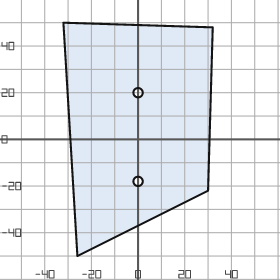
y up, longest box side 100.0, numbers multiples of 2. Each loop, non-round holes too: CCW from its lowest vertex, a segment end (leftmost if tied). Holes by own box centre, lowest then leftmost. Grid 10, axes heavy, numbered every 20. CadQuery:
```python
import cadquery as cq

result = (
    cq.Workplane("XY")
    .moveTo(-26.0, -50.0)
    .lineTo(30.0, -22.0)
    .lineTo(32.0, 48.0)
    .lineTo(-32.0, 50.0)
    .close()
    .moveTo(0.0, -18.0)
    .circle(2.0)
    .moveTo(0.0, 20.0)
    .circle(2.0)
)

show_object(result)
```